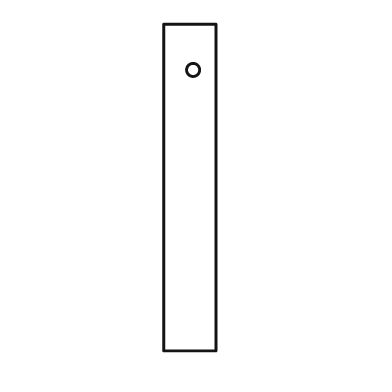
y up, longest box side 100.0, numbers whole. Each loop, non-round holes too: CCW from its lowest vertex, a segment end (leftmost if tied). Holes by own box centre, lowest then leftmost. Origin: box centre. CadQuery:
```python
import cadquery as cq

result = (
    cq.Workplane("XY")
    .moveTo(-8.0, -50.0)
    .lineTo(8.0, -50.0)
    .lineTo(8.0, 50.0)
    .lineTo(-8.0, 50.0)
    .close()
    .moveTo(1.0, 36.0)
    .circle(2.0)
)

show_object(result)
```